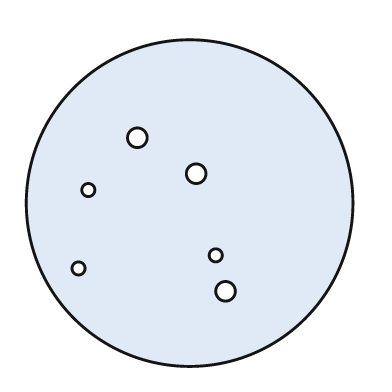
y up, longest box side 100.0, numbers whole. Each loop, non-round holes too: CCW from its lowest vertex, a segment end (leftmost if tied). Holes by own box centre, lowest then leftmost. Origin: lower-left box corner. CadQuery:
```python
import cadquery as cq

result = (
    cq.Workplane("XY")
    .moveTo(50.0, 50.0)
    .circle(50.0)
    .moveTo(61.0, 23.0)
    .circle(3.0)
    .moveTo(16.0, 30.0)
    .circle(2.0)
    .moveTo(58.0, 34.0)
    .circle(2.0)
    .moveTo(19.0, 54.0)
    .circle(2.0)
    .moveTo(52.0, 59.0)
    .circle(3.0)
    .moveTo(34.0, 70.0)
    .circle(3.0)
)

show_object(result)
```